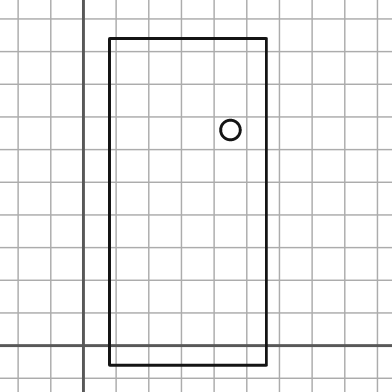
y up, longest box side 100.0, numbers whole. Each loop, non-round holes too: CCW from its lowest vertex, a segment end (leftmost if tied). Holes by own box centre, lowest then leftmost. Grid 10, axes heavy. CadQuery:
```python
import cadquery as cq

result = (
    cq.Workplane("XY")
    .moveTo(8.0, -6.0)
    .lineTo(56.0, -6.0)
    .lineTo(56.0, 94.0)
    .lineTo(8.0, 94.0)
    .close()
    .moveTo(45.0, 66.0)
    .circle(3.0)
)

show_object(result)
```